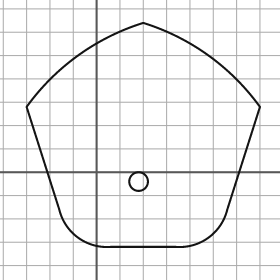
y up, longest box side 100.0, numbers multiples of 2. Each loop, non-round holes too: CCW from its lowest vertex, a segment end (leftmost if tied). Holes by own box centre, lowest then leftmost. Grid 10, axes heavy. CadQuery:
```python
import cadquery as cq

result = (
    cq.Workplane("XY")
    .moveTo(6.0, -32.0)
    .lineTo(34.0, -32.0)
    .threePointArc((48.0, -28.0), (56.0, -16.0))
    .lineTo(70.0, 28.0)
    .threePointArc((48.0, 50.0), (20.0, 64.0))
    .threePointArc((-8.0, 50.0), (-30.0, 28.0))
    .lineTo(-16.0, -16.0)
    .threePointArc((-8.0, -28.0), (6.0, -32.0))
    .close()
    .moveTo(18.0, -4.0)
    .circle(4.0)
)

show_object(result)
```